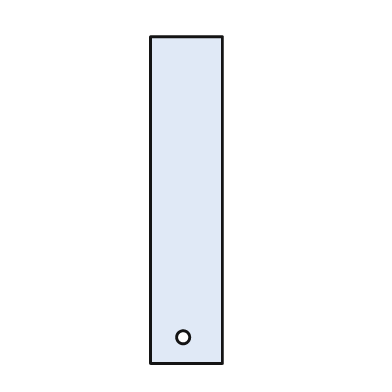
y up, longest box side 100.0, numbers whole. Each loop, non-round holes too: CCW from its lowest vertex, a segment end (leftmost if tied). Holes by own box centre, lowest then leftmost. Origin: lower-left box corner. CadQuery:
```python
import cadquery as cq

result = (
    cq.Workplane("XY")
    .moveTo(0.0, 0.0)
    .lineTo(22.0, 0.0)
    .lineTo(22.0, 100.0)
    .lineTo(0.0, 100.0)
    .close()
    .moveTo(10.0, 8.0)
    .circle(2.0)
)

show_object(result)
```